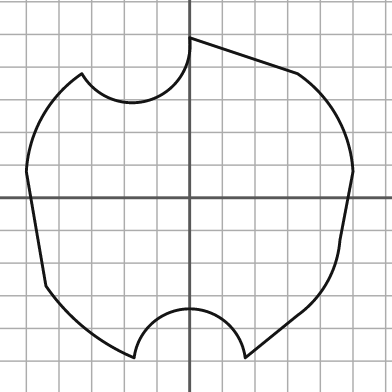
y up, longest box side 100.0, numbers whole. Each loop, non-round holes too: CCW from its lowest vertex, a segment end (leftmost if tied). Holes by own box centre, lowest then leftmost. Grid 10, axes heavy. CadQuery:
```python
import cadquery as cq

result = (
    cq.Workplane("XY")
    .moveTo(-17.0, -49.0)
    .threePointArc((0.0, -34.0), (17.0, -49.0))
    .lineTo(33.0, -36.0)
    .threePointArc((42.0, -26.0), (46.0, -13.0))
    .lineTo(50.0, 8.0)
    .threePointArc((45.0, 25.0), (33.0, 38.0))
    .lineTo(0.0, 49.0)
    .threePointArc((-12.0, 30.0), (-33.0, 38.0))
    .threePointArc((-45.0, 25.0), (-50.0, 8.0))
    .lineTo(-44.0, -27.0)
    .threePointArc((-32.0, -40.0), (-17.0, -49.0))
    .close()
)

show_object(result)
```